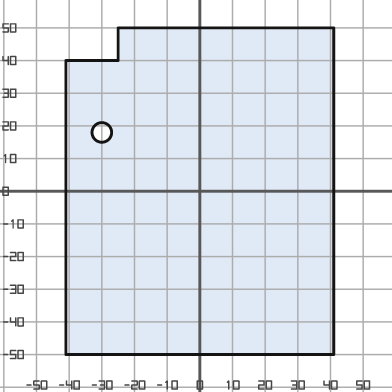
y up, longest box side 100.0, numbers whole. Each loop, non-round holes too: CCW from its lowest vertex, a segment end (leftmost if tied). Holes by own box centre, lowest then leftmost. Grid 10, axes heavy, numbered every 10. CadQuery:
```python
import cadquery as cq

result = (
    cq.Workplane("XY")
    .moveTo(-41.0, -50.0)
    .lineTo(41.0, -50.0)
    .lineTo(41.0, 50.0)
    .lineTo(-25.0, 50.0)
    .lineTo(-25.0, 40.0)
    .lineTo(-41.0, 40.0)
    .close()
    .moveTo(-30.0, 18.0)
    .circle(3.0)
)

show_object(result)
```